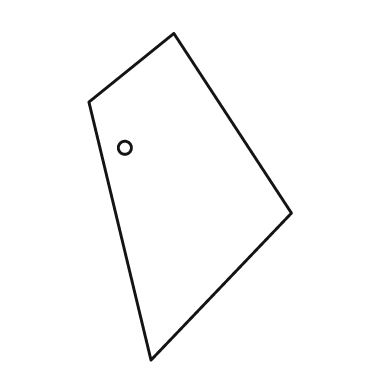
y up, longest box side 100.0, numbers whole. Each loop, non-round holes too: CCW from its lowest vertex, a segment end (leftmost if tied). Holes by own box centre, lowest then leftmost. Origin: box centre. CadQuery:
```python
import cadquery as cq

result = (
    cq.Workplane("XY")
    .moveTo(-12.0, -50.0)
    .lineTo(31.0, -5.0)
    .lineTo(-5.0, 50.0)
    .lineTo(-31.0, 29.0)
    .close()
    .moveTo(-20.0, 15.0)
    .circle(2.0)
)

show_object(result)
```